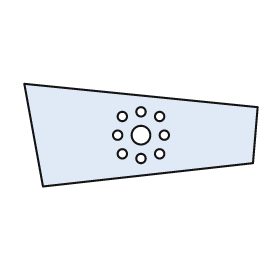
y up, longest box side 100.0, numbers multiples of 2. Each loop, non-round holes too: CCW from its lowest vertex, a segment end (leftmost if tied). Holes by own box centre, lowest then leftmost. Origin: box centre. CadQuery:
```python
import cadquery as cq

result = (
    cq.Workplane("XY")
    .moveTo(-42.0, -22.0)
    .lineTo(48.0, -12.0)
    .lineTo(50.0, 12.0)
    .lineTo(-50.0, 22.0)
    .close()
    .moveTo(0.0, -10.0)
    .circle(2.0)
    .moveTo(-8.0, -8.0)
    .circle(2.0)
    .moveTo(8.0, -8.0)
    .circle(2.0)
    .moveTo(-10.0, 0.0)
    .circle(2.0)
    .moveTo(0.0, 0.0)
    .circle(4.0)
    .moveTo(10.0, 0.0)
    .circle(2.0)
    .moveTo(-8.0, 8.0)
    .circle(2.0)
    .moveTo(8.0, 8.0)
    .circle(2.0)
    .moveTo(0.0, 10.0)
    .circle(2.0)
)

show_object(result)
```